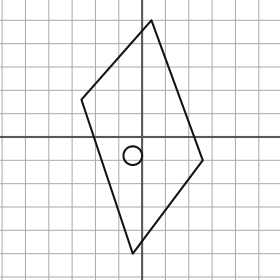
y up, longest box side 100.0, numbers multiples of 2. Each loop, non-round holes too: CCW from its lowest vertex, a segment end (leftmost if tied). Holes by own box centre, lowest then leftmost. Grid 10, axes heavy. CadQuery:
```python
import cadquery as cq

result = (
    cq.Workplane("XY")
    .moveTo(-4.0, -50.0)
    .lineTo(26.0, -10.0)
    .lineTo(4.0, 50.0)
    .lineTo(-26.0, 16.0)
    .close()
    .moveTo(-4.0, -8.0)
    .circle(4.0)
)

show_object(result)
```